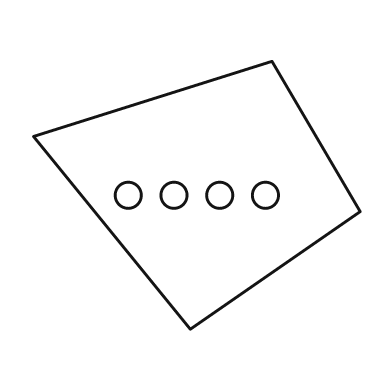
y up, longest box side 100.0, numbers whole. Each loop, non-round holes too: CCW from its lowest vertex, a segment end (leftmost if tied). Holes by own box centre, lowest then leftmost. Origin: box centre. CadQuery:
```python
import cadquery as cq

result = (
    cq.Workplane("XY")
    .moveTo(-2.0, -41.0)
    .lineTo(50.0, -5.0)
    .lineTo(23.0, 41.0)
    .lineTo(-50.0, 18.0)
    .close()
    .moveTo(-21.0, 0.0)
    .circle(4.0)
    .moveTo(-7.0, 0.0)
    .circle(4.0)
    .moveTo(7.0, 0.0)
    .circle(4.0)
    .moveTo(21.0, 0.0)
    .circle(4.0)
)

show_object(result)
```